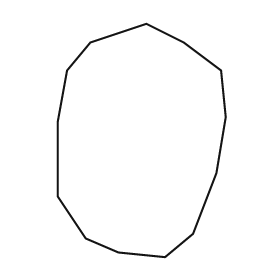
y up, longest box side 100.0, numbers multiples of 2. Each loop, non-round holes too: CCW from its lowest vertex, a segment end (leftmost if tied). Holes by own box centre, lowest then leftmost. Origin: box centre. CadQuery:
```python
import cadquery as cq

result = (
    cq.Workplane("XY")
    .moveTo(10.0, -50.0)
    .lineTo(22.0, -40.0)
    .lineTo(32.0, -14.0)
    .lineTo(36.0, 10.0)
    .lineTo(34.0, 30.0)
    .lineTo(18.0, 42.0)
    .lineTo(2.0, 50.0)
    .lineTo(-22.0, 42.0)
    .lineTo(-32.0, 30.0)
    .lineTo(-36.0, 8.0)
    .lineTo(-36.0, -24.0)
    .lineTo(-24.0, -42.0)
    .lineTo(-10.0, -48.0)
    .close()
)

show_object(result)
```